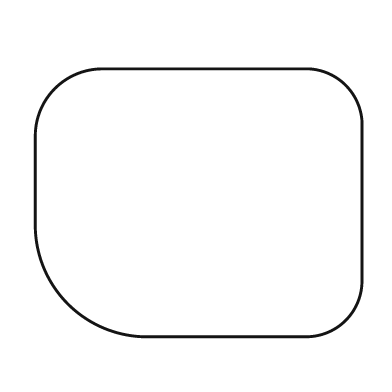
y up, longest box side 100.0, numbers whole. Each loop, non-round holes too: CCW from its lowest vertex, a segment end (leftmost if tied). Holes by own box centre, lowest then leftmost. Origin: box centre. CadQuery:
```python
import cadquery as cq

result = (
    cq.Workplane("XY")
    .moveTo(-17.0, -41.0)
    .lineTo(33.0, -41.0)
    .threePointArc((45.0, -36.0), (50.0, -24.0))
    .lineTo(50.0, 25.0)
    .threePointArc((45.0, 36.0), (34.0, 41.0))
    .lineTo(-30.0, 41.0)
    .threePointArc((-44.0, 35.0), (-50.0, 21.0))
    .lineTo(-50.0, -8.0)
    .threePointArc((-40.0, -31.0), (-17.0, -41.0))
    .close()
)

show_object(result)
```